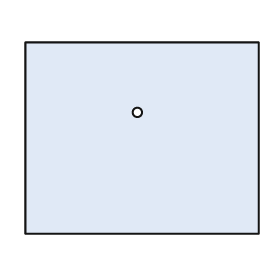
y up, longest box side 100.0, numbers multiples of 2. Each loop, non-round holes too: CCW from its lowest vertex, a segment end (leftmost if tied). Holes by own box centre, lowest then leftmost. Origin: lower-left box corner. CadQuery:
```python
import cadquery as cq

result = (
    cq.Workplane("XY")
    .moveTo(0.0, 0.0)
    .lineTo(100.0, 0.0)
    .lineTo(100.0, 82.0)
    .lineTo(0.0, 82.0)
    .close()
    .moveTo(48.0, 52.0)
    .circle(2.0)
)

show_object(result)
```